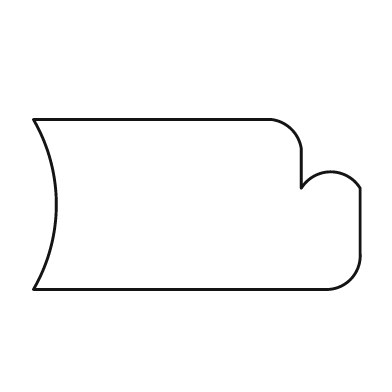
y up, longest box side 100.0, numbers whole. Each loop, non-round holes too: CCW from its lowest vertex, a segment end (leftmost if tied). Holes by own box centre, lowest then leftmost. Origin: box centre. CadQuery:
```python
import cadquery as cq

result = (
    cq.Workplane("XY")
    .moveTo(-50.0, -26.0)
    .lineTo(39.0, -26.0)
    .threePointArc((47.0, -23.0), (50.0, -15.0))
    .lineTo(50.0, 5.0)
    .threePointArc((41.0, 10.0), (32.0, 5.0))
    .lineTo(32.0, 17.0)
    .threePointArc((29.0, 23.0), (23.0, 26.0))
    .lineTo(-50.0, 26.0)
    .threePointArc((-43.0, 0.0), (-50.0, -26.0))
    .close()
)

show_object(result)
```